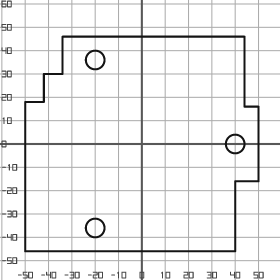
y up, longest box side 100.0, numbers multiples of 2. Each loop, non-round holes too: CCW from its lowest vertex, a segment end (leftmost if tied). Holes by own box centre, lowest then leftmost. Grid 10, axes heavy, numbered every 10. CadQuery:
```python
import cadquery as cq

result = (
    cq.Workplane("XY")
    .moveTo(-50.0, -46.0)
    .lineTo(40.0, -46.0)
    .lineTo(40.0, -16.0)
    .lineTo(50.0, -16.0)
    .lineTo(50.0, 16.0)
    .lineTo(44.0, 16.0)
    .lineTo(44.0, 46.0)
    .lineTo(-34.0, 46.0)
    .lineTo(-34.0, 30.0)
    .lineTo(-42.0, 30.0)
    .lineTo(-42.0, 18.0)
    .lineTo(-50.0, 18.0)
    .close()
    .moveTo(-20.0, -36.0)
    .circle(4.0)
    .moveTo(40.0, 0.0)
    .circle(4.0)
    .moveTo(-20.0, 36.0)
    .circle(4.0)
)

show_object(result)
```